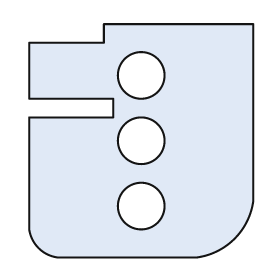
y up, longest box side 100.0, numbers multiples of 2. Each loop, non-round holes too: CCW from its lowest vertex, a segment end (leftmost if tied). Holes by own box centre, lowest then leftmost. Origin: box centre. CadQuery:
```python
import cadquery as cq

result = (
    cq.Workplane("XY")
    .moveTo(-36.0, -50.0)
    .lineTo(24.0, -50.0)
    .threePointArc((40.0, -42.0), (48.0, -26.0))
    .lineTo(48.0, 50.0)
    .lineTo(-16.0, 50.0)
    .lineTo(-16.0, 42.0)
    .lineTo(-48.0, 42.0)
    .lineTo(-48.0, 18.0)
    .lineTo(-12.0, 18.0)
    .lineTo(-12.0, 10.0)
    .lineTo(-48.0, 10.0)
    .lineTo(-48.0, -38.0)
    .threePointArc((-44.0, -46.0), (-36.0, -50.0))
    .close()
    .moveTo(0.0, -28.0)
    .circle(10.0)
    .moveTo(0.0, 0.0)
    .circle(10.0)
    .moveTo(0.0, 28.0)
    .circle(10.0)
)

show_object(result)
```